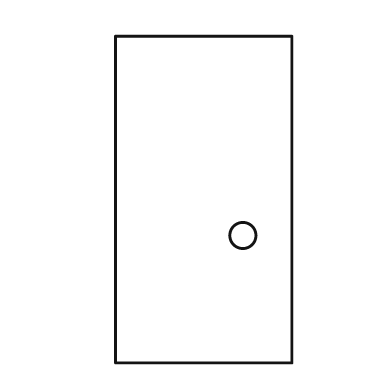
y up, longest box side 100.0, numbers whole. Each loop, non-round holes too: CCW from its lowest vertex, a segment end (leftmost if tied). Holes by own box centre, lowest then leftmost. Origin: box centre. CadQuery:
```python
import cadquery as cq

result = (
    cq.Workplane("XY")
    .moveTo(-27.0, -50.0)
    .lineTo(27.0, -50.0)
    .lineTo(27.0, 50.0)
    .lineTo(-27.0, 50.0)
    .close()
    .moveTo(12.0, -11.0)
    .circle(4.0)
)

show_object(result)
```